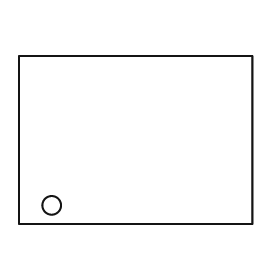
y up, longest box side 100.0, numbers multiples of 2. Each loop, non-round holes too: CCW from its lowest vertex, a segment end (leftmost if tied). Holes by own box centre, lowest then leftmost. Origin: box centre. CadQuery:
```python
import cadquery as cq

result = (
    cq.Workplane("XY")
    .moveTo(-50.0, -36.0)
    .lineTo(50.0, -36.0)
    .lineTo(50.0, 36.0)
    .lineTo(-50.0, 36.0)
    .close()
    .moveTo(-36.0, -28.0)
    .circle(4.0)
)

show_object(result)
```